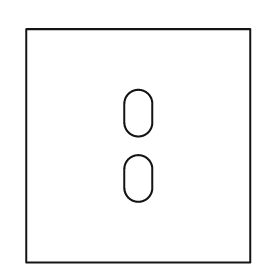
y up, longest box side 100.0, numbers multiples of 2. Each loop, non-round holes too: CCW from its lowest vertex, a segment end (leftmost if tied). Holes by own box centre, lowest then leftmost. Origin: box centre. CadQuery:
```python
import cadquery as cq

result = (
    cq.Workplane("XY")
    .moveTo(-48.0, -50.0)
    .lineTo(48.0, -50.0)
    .lineTo(48.0, 50.0)
    .lineTo(-48.0, 50.0)
    .close()
    .moveTo(-6.0, -18.0)
    .threePointArc((0.0, -24.0), (6.0, -18.0))
    .lineTo(6.0, -10.0)
    .threePointArc((0.0, -4.0), (-6.0, -10.0))
    .close()
    .moveTo(-6.0, 10.0)
    .threePointArc((0.0, 4.0), (6.0, 10.0))
    .lineTo(6.0, 18.0)
    .threePointArc((0.0, 24.0), (-6.0, 18.0))
    .close()
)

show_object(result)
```